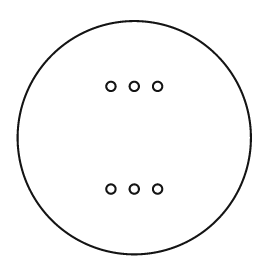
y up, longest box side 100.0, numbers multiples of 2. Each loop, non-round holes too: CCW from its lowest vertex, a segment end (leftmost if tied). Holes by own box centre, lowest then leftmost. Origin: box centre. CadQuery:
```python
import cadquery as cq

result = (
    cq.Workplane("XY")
    .moveTo(0.0, 0.0)
    .circle(50.0)
    .moveTo(-10.0, -22.0)
    .circle(2.0)
    .moveTo(0.0, -22.0)
    .circle(2.0)
    .moveTo(10.0, -22.0)
    .circle(2.0)
    .moveTo(-10.0, 22.0)
    .circle(2.0)
    .moveTo(0.0, 22.0)
    .circle(2.0)
    .moveTo(10.0, 22.0)
    .circle(2.0)
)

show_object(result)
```